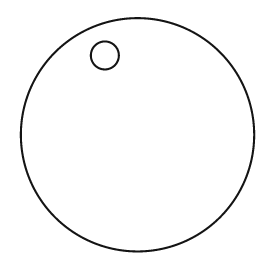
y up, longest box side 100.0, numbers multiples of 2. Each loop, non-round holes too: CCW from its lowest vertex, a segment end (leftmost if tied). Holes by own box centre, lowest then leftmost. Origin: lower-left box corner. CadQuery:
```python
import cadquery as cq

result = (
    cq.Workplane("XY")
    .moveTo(50.0, 50.0)
    .circle(50.0)
    .moveTo(36.0, 84.0)
    .circle(6.0)
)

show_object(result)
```